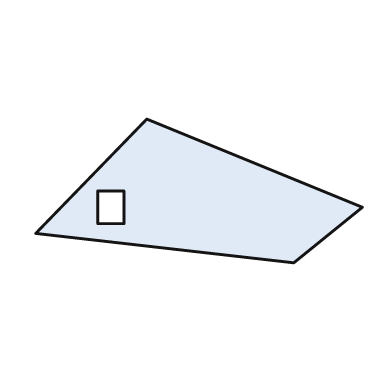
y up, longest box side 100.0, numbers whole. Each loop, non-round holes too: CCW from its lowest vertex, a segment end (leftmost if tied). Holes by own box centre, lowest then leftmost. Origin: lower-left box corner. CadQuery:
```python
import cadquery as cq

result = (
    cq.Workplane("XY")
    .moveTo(79.0, 0.0)
    .lineTo(100.0, 17.0)
    .lineTo(34.0, 44.0)
    .lineTo(0.0, 9.0)
    .close()
    .moveTo(19.0, 12.0)
    .lineTo(27.0, 12.0)
    .lineTo(27.0, 22.0)
    .lineTo(19.0, 22.0)
    .close()
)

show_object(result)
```